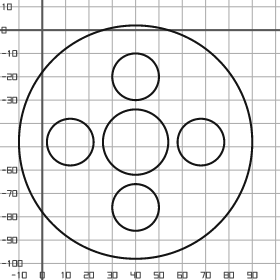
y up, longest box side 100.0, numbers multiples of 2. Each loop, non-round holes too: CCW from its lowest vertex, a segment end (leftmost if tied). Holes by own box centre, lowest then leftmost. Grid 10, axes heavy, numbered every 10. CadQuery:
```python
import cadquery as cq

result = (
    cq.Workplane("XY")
    .moveTo(40.0, -48.0)
    .circle(50.0)
    .moveTo(40.0, -76.0)
    .circle(10.0)
    .moveTo(12.0, -48.0)
    .circle(10.0)
    .moveTo(40.0, -48.0)
    .circle(14.0)
    .moveTo(68.0, -48.0)
    .circle(10.0)
    .moveTo(40.0, -20.0)
    .circle(10.0)
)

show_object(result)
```